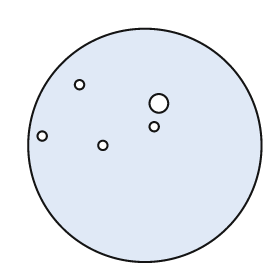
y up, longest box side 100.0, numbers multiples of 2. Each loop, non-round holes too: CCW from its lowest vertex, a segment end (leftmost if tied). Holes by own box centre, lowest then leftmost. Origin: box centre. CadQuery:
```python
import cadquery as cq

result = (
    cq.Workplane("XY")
    .moveTo(0.0, 0.0)
    .circle(50.0)
    .moveTo(-18.0, 0.0)
    .circle(2.0)
    .moveTo(-44.0, 4.0)
    .circle(2.0)
    .moveTo(4.0, 8.0)
    .circle(2.0)
    .moveTo(6.0, 18.0)
    .circle(4.0)
    .moveTo(-28.0, 26.0)
    .circle(2.0)
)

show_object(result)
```